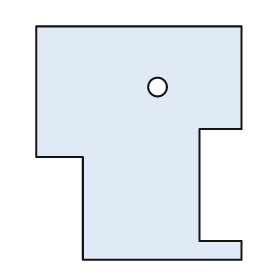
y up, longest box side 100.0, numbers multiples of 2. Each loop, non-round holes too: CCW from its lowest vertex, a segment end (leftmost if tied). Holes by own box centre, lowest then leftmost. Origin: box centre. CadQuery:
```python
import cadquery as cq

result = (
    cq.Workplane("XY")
    .moveTo(-24.0, -50.0)
    .lineTo(44.0, -50.0)
    .lineTo(44.0, -42.0)
    .lineTo(26.0, -42.0)
    .lineTo(26.0, 6.0)
    .lineTo(44.0, 6.0)
    .lineTo(44.0, 50.0)
    .lineTo(-44.0, 50.0)
    .lineTo(-44.0, -6.0)
    .lineTo(-24.0, -6.0)
    .close()
    .moveTo(8.0, 24.0)
    .circle(4.0)
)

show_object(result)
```